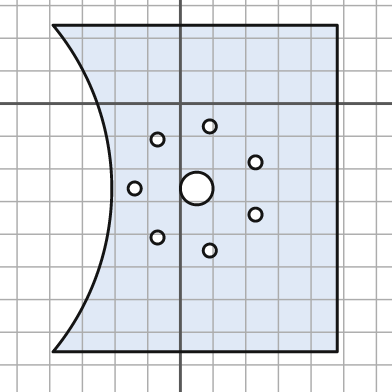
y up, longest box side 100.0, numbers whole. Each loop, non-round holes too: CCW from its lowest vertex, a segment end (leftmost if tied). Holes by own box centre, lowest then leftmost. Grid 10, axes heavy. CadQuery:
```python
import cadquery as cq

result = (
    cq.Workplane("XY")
    .moveTo(-39.0, -76.0)
    .lineTo(48.0, -76.0)
    .lineTo(48.0, 24.0)
    .lineTo(-39.0, 24.0)
    .threePointArc((-21.0, -26.0), (-39.0, -76.0))
    .close()
    .moveTo(9.0, -45.0)
    .circle(2.0)
    .moveTo(-7.0, -41.0)
    .circle(2.0)
    .moveTo(23.0, -34.0)
    .circle(2.0)
    .moveTo(-14.0, -26.0)
    .circle(2.0)
    .moveTo(5.0, -26.0)
    .circle(5.0)
    .moveTo(23.0, -18.0)
    .circle(2.0)
    .moveTo(-7.0, -11.0)
    .circle(2.0)
    .moveTo(9.0, -7.0)
    .circle(2.0)
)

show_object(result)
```